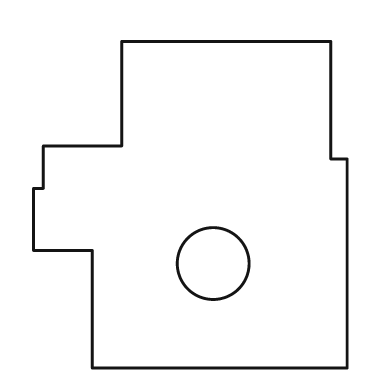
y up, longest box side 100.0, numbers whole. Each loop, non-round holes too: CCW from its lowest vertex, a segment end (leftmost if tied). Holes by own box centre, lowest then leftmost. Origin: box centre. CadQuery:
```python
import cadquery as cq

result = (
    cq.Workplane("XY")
    .moveTo(-30.0, -50.0)
    .lineTo(48.0, -50.0)
    .lineTo(48.0, 14.0)
    .lineTo(43.0, 14.0)
    .lineTo(43.0, 50.0)
    .lineTo(-21.0, 50.0)
    .lineTo(-21.0, 18.0)
    .lineTo(-45.0, 18.0)
    .lineTo(-45.0, 5.0)
    .lineTo(-48.0, 5.0)
    .lineTo(-48.0, -14.0)
    .lineTo(-30.0, -14.0)
    .close()
    .moveTo(7.0, -18.0)
    .circle(11.0)
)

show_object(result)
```